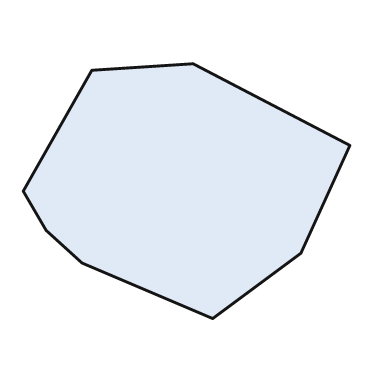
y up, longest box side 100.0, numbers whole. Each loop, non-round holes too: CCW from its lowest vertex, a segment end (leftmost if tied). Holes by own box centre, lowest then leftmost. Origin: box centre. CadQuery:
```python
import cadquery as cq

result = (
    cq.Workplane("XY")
    .moveTo(8.0, -39.0)
    .lineTo(35.0, -19.0)
    .lineTo(50.0, 14.0)
    .lineTo(2.0, 39.0)
    .lineTo(-29.0, 37.0)
    .lineTo(-50.0, 0.0)
    .lineTo(-43.0, -12.0)
    .lineTo(-32.0, -22.0)
    .close()
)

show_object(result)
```